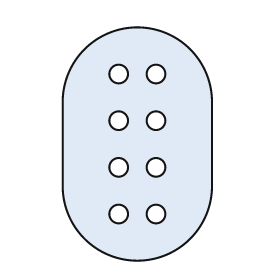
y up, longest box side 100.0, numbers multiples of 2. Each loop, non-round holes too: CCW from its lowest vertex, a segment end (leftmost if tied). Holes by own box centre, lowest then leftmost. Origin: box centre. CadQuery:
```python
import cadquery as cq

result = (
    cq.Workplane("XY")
    .moveTo(-32.0, -18.0)
    .threePointArc((0.0, -50.0), (32.0, -18.0))
    .lineTo(32.0, 18.0)
    .threePointArc((0.0, 50.0), (-32.0, 18.0))
    .close()
    .moveTo(-8.0, -30.0)
    .circle(4.0)
    .moveTo(8.0, -30.0)
    .circle(4.0)
    .moveTo(-8.0, -10.0)
    .circle(4.0)
    .moveTo(8.0, -10.0)
    .circle(4.0)
    .moveTo(-8.0, 10.0)
    .circle(4.0)
    .moveTo(8.0, 10.0)
    .circle(4.0)
    .moveTo(-8.0, 30.0)
    .circle(4.0)
    .moveTo(8.0, 30.0)
    .circle(4.0)
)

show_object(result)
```